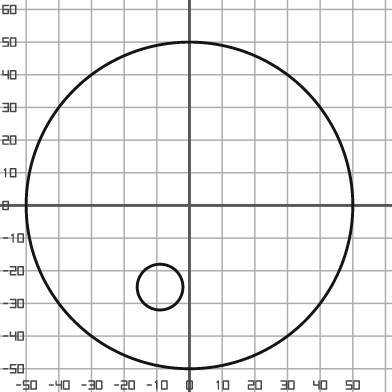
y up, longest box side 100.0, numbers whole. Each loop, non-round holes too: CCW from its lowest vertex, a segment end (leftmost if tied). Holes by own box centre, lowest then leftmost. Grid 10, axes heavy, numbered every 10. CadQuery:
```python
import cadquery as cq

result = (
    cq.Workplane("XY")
    .moveTo(0.0, 0.0)
    .circle(50.0)
    .moveTo(-9.0, -25.0)
    .circle(7.0)
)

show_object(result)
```